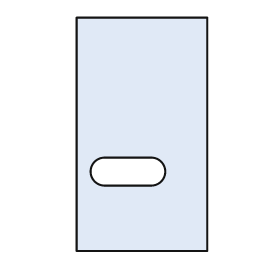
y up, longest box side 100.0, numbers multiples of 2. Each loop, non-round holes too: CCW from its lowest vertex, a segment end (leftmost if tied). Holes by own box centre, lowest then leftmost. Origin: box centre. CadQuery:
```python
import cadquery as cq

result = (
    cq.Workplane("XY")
    .moveTo(-28.0, -50.0)
    .lineTo(28.0, -50.0)
    .lineTo(28.0, 50.0)
    .lineTo(-28.0, 50.0)
    .close()
    .moveTo(-16.0, -22.0)
    .lineTo(4.0, -22.0)
    .threePointArc((10.0, -16.0), (4.0, -10.0))
    .lineTo(-16.0, -10.0)
    .threePointArc((-22.0, -16.0), (-16.0, -22.0))
    .close()
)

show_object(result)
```